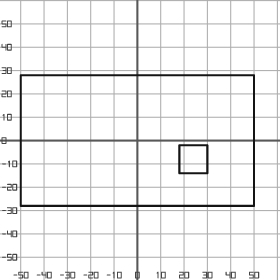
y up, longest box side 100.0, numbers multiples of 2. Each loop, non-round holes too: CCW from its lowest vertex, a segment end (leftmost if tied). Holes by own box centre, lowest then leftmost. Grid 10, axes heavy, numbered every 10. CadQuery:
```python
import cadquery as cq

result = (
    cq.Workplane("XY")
    .moveTo(-50.0, -28.0)
    .lineTo(50.0, -28.0)
    .lineTo(50.0, 28.0)
    .lineTo(-50.0, 28.0)
    .close()
    .moveTo(18.0, -14.0)
    .lineTo(30.0, -14.0)
    .lineTo(30.0, -2.0)
    .lineTo(18.0, -2.0)
    .close()
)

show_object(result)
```